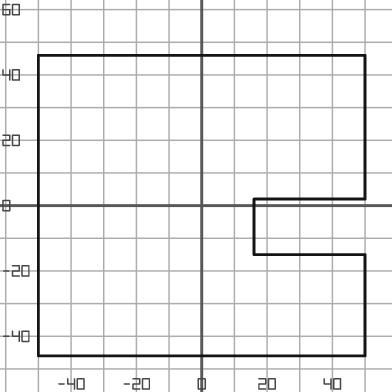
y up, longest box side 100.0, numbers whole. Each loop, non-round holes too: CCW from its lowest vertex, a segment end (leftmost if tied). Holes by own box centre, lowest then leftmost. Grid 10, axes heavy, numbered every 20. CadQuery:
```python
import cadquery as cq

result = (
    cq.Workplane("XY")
    .moveTo(-50.0, -46.0)
    .lineTo(50.0, -46.0)
    .lineTo(50.0, -15.0)
    .lineTo(16.0, -15.0)
    .lineTo(16.0, 2.0)
    .lineTo(50.0, 2.0)
    .lineTo(50.0, 46.0)
    .lineTo(-50.0, 46.0)
    .close()
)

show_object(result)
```